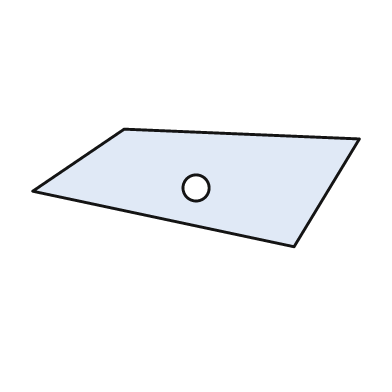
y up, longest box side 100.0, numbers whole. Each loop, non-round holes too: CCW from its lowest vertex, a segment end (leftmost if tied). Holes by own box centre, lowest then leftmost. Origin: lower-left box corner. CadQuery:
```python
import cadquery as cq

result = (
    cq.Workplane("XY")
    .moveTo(80.0, 0.0)
    .lineTo(100.0, 33.0)
    .lineTo(28.0, 36.0)
    .lineTo(0.0, 17.0)
    .close()
    .moveTo(50.0, 18.0)
    .circle(4.0)
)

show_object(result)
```